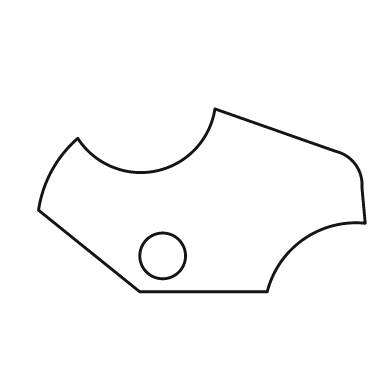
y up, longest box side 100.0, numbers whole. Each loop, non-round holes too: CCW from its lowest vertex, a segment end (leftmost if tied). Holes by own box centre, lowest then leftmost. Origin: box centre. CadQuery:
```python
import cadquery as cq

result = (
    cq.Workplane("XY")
    .moveTo(-19.0, -28.0)
    .lineTo(20.0, -28.0)
    .threePointArc((31.0, -12.0), (50.0, -7.0))
    .lineTo(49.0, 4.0)
    .threePointArc((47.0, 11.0), (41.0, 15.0))
    .lineTo(4.0, 28.0)
    .threePointArc((-14.0, 9.0), (-38.0, 19.0))
    .threePointArc((-46.0, 9.0), (-50.0, -3.0))
    .close()
    .moveTo(-12.0, -17.0)
    .circle(7.0)
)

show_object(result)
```